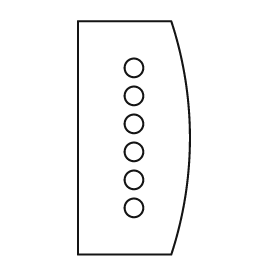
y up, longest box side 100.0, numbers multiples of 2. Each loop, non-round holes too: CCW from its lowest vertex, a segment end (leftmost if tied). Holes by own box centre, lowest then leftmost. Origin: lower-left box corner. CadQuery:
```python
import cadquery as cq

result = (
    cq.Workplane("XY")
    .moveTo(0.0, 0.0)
    .lineTo(40.0, 0.0)
    .threePointArc((48.0, 50.0), (40.0, 100.0))
    .lineTo(0.0, 100.0)
    .close()
    .moveTo(24.0, 20.0)
    .circle(4.0)
    .moveTo(24.0, 32.0)
    .circle(4.0)
    .moveTo(24.0, 44.0)
    .circle(4.0)
    .moveTo(24.0, 56.0)
    .circle(4.0)
    .moveTo(24.0, 68.0)
    .circle(4.0)
    .moveTo(24.0, 80.0)
    .circle(4.0)
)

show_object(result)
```